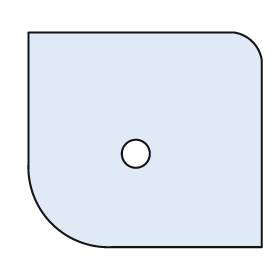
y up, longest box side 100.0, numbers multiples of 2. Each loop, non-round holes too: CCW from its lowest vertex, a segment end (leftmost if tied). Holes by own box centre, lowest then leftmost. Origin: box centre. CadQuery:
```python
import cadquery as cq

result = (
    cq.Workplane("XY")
    .moveTo(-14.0, -46.0)
    .lineTo(50.0, -46.0)
    .lineTo(50.0, 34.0)
    .threePointArc((46.0, 42.0), (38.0, 46.0))
    .lineTo(-50.0, 46.0)
    .lineTo(-50.0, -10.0)
    .threePointArc((-40.0, -36.0), (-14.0, -46.0))
    .close()
    .moveTo(-4.0, -6.0)
    .circle(6.0)
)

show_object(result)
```